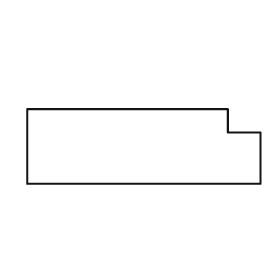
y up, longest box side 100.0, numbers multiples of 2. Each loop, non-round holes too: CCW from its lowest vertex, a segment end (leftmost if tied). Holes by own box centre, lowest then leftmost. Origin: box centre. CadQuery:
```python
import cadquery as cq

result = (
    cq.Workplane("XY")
    .moveTo(-50.0, -16.0)
    .lineTo(50.0, -16.0)
    .lineTo(50.0, 6.0)
    .lineTo(36.0, 6.0)
    .lineTo(36.0, 16.0)
    .lineTo(-50.0, 16.0)
    .close()
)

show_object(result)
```